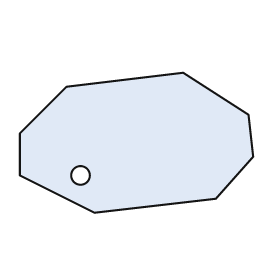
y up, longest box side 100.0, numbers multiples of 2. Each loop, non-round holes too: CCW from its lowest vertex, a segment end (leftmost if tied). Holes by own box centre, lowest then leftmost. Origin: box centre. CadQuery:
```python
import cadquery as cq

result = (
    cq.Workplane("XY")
    .moveTo(-18.0, -30.0)
    .lineTo(34.0, -24.0)
    .lineTo(50.0, -6.0)
    .lineTo(48.0, 12.0)
    .lineTo(20.0, 30.0)
    .lineTo(-30.0, 24.0)
    .lineTo(-50.0, 4.0)
    .lineTo(-50.0, -14.0)
    .close()
    .moveTo(-24.0, -14.0)
    .circle(4.0)
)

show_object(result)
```